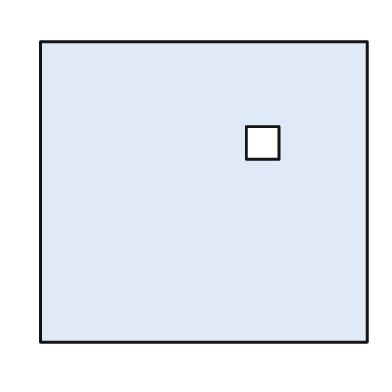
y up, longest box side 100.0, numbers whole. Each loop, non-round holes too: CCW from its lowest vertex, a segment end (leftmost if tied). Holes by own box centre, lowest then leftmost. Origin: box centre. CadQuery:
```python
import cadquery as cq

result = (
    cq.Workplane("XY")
    .moveTo(-50.0, -46.0)
    .lineTo(50.0, -46.0)
    .lineTo(50.0, 46.0)
    .lineTo(-50.0, 46.0)
    .close()
    .moveTo(13.0, 10.0)
    .lineTo(23.0, 10.0)
    .lineTo(23.0, 20.0)
    .lineTo(13.0, 20.0)
    .close()
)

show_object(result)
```